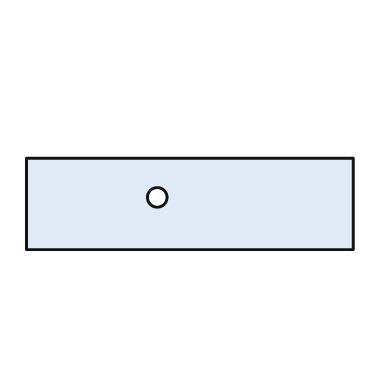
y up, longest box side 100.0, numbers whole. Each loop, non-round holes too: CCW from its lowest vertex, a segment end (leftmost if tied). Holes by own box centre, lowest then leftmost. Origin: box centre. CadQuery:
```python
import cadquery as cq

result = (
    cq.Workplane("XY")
    .moveTo(-50.0, -14.0)
    .lineTo(50.0, -14.0)
    .lineTo(50.0, 14.0)
    .lineTo(-50.0, 14.0)
    .close()
    .moveTo(-10.0, 2.0)
    .circle(3.0)
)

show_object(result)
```